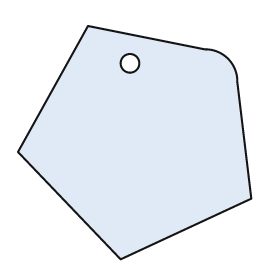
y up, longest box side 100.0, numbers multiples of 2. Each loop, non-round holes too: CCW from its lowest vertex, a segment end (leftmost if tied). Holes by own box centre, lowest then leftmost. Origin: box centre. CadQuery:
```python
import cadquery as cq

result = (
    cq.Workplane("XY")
    .moveTo(-6.0, -50.0)
    .lineTo(50.0, -24.0)
    .lineTo(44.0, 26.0)
    .threePointArc((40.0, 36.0), (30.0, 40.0))
    .lineTo(-20.0, 50.0)
    .lineTo(-50.0, -4.0)
    .close()
    .moveTo(-2.0, 34.0)
    .circle(4.0)
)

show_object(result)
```